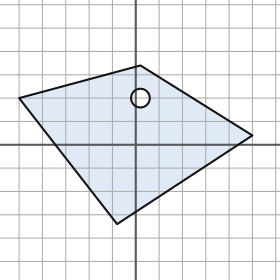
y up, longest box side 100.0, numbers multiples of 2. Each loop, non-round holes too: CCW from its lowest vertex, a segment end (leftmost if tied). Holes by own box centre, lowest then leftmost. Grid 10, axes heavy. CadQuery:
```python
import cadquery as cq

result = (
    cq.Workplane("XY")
    .moveTo(-8.0, -34.0)
    .lineTo(50.0, 4.0)
    .lineTo(2.0, 34.0)
    .lineTo(-50.0, 20.0)
    .close()
    .moveTo(2.0, 20.0)
    .circle(4.0)
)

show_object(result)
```